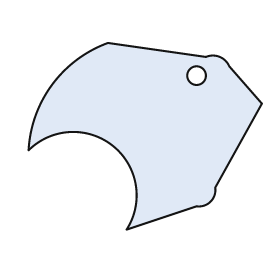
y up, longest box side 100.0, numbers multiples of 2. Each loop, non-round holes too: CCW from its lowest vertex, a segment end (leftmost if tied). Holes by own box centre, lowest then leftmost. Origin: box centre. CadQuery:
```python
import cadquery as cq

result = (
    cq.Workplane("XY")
    .moveTo(-8.0, -40.0)
    .lineTo(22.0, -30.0)
    .threePointArc((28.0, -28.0), (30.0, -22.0))
    .lineTo(50.0, 14.0)
    .lineTo(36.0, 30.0)
    .threePointArc((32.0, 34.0), (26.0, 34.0))
    .lineTo(-16.0, 40.0)
    .threePointArc((-40.0, 22.0), (-50.0, -6.0))
    .threePointArc((-14.0, -4.0), (-8.0, -40.0))
    .close()
    .moveTo(22.0, 26.0)
    .circle(4.0)
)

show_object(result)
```